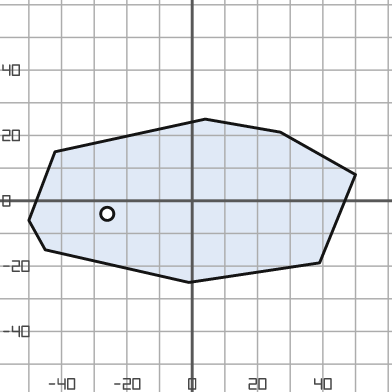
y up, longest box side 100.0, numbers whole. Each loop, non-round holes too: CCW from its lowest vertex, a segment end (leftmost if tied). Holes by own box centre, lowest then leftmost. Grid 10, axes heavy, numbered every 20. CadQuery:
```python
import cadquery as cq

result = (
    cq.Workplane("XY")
    .moveTo(-1.0, -25.0)
    .lineTo(39.0, -19.0)
    .lineTo(50.0, 8.0)
    .lineTo(27.0, 21.0)
    .lineTo(4.0, 25.0)
    .lineTo(-42.0, 15.0)
    .lineTo(-50.0, -6.0)
    .lineTo(-45.0, -15.0)
    .close()
    .moveTo(-26.0, -4.0)
    .circle(2.0)
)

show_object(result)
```